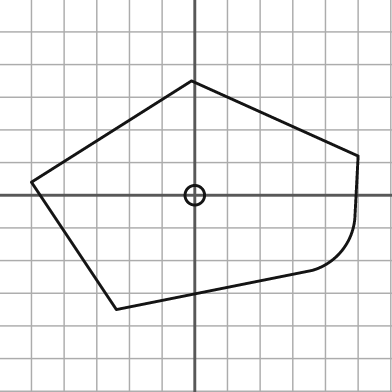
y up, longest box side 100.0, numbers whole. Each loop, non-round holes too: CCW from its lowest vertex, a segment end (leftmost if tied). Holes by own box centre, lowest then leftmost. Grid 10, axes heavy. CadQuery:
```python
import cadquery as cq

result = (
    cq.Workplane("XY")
    .moveTo(-24.0, -35.0)
    .lineTo(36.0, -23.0)
    .threePointArc((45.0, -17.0), (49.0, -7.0))
    .lineTo(50.0, 12.0)
    .lineTo(-1.0, 35.0)
    .lineTo(-50.0, 4.0)
    .close()
    .moveTo(0.0, 0.0)
    .circle(3.0)
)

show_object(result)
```